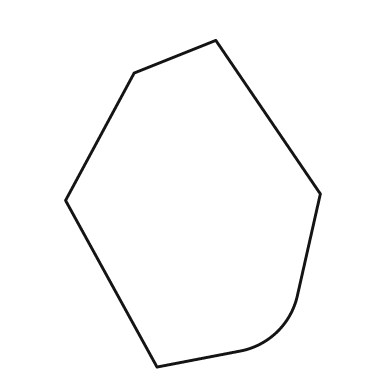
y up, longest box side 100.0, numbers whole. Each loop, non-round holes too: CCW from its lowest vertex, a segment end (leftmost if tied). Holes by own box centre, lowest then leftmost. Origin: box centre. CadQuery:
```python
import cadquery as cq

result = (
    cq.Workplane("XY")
    .moveTo(-11.0, -50.0)
    .lineTo(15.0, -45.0)
    .threePointArc((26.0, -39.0), (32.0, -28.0))
    .lineTo(39.0, 3.0)
    .lineTo(7.0, 50.0)
    .lineTo(-18.0, 40.0)
    .lineTo(-39.0, 1.0)
    .close()
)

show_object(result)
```